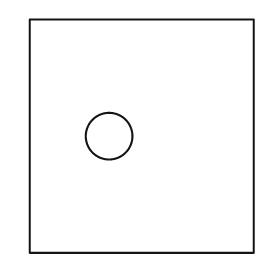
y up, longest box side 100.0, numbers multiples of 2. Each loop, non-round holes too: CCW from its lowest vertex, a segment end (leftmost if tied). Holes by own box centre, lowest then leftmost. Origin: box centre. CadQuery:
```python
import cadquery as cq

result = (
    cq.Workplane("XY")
    .moveTo(-48.0, -50.0)
    .lineTo(48.0, -50.0)
    .lineTo(48.0, 50.0)
    .lineTo(-48.0, 50.0)
    .close()
    .moveTo(-14.0, 0.0)
    .circle(10.0)
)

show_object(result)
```